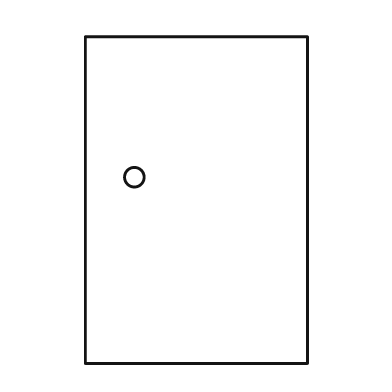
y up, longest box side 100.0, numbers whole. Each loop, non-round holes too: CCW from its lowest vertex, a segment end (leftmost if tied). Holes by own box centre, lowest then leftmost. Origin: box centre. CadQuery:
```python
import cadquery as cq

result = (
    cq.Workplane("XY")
    .moveTo(-34.0, -50.0)
    .lineTo(34.0, -50.0)
    .lineTo(34.0, 50.0)
    .lineTo(-34.0, 50.0)
    .close()
    .moveTo(-19.0, 7.0)
    .circle(3.0)
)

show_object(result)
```